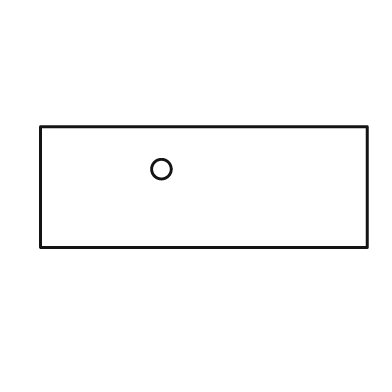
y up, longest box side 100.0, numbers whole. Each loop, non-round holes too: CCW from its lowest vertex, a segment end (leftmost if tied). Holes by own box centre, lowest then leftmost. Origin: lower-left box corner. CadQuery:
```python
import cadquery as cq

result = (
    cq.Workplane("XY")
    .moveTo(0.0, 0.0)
    .lineTo(100.0, 0.0)
    .lineTo(100.0, 37.0)
    .lineTo(0.0, 37.0)
    .close()
    .moveTo(37.0, 24.0)
    .circle(3.0)
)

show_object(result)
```